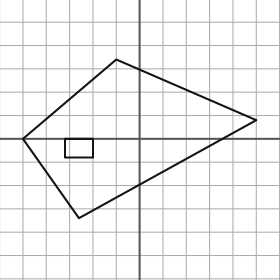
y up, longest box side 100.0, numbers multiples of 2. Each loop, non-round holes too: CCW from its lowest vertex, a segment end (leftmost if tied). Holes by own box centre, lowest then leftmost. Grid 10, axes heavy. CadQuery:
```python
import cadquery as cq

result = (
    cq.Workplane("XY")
    .moveTo(-26.0, -34.0)
    .lineTo(50.0, 8.0)
    .lineTo(-10.0, 34.0)
    .lineTo(-50.0, 0.0)
    .close()
    .moveTo(-32.0, -8.0)
    .lineTo(-20.0, -8.0)
    .lineTo(-20.0, 0.0)
    .lineTo(-32.0, 0.0)
    .close()
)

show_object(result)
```